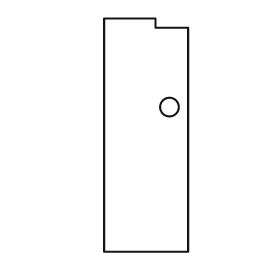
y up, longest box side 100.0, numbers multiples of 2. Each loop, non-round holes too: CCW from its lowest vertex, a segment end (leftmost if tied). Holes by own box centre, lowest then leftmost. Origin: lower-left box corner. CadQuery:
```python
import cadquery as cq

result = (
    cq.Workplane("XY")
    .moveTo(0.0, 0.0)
    .lineTo(36.0, 0.0)
    .lineTo(36.0, 96.0)
    .lineTo(22.0, 96.0)
    .lineTo(22.0, 100.0)
    .lineTo(0.0, 100.0)
    .close()
    .moveTo(28.0, 62.0)
    .circle(4.0)
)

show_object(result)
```